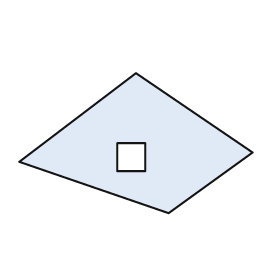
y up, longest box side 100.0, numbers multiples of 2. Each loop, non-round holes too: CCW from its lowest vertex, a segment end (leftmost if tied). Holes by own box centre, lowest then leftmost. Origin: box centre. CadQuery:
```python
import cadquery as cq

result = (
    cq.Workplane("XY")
    .moveTo(14.0, -30.0)
    .lineTo(50.0, -4.0)
    .lineTo(0.0, 30.0)
    .lineTo(-50.0, -8.0)
    .close()
    .moveTo(-8.0, -12.0)
    .lineTo(4.0, -12.0)
    .lineTo(4.0, 0.0)
    .lineTo(-8.0, 0.0)
    .close()
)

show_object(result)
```